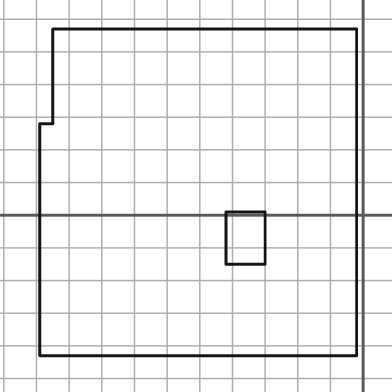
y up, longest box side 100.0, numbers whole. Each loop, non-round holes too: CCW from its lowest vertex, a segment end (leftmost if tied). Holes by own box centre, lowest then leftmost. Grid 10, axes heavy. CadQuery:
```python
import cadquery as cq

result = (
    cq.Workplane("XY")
    .moveTo(-99.0, -43.0)
    .lineTo(-2.0, -43.0)
    .lineTo(-2.0, 57.0)
    .lineTo(-95.0, 57.0)
    .lineTo(-95.0, 28.0)
    .lineTo(-99.0, 28.0)
    .close()
    .moveTo(-42.0, -15.0)
    .lineTo(-30.0, -15.0)
    .lineTo(-30.0, 1.0)
    .lineTo(-42.0, 1.0)
    .close()
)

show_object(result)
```